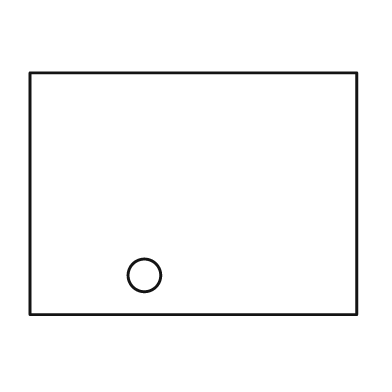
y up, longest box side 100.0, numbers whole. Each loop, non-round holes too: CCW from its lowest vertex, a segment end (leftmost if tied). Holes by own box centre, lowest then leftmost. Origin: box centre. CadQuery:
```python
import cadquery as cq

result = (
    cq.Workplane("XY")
    .moveTo(-50.0, -37.0)
    .lineTo(50.0, -37.0)
    .lineTo(50.0, 37.0)
    .lineTo(-50.0, 37.0)
    .close()
    .moveTo(-15.0, -25.0)
    .circle(5.0)
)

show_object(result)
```